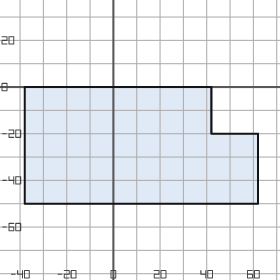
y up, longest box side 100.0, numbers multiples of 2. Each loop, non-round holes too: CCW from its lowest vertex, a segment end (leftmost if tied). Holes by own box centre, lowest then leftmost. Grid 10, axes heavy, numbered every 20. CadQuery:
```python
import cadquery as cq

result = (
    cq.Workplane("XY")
    .moveTo(-38.0, -50.0)
    .lineTo(62.0, -50.0)
    .lineTo(62.0, -20.0)
    .lineTo(42.0, -20.0)
    .lineTo(42.0, 0.0)
    .lineTo(-38.0, 0.0)
    .close()
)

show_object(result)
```